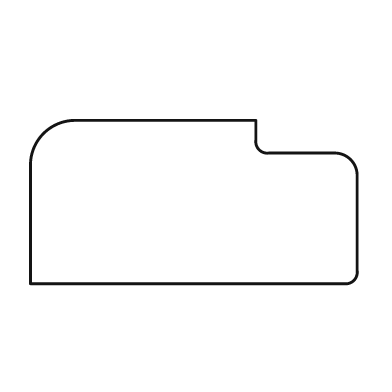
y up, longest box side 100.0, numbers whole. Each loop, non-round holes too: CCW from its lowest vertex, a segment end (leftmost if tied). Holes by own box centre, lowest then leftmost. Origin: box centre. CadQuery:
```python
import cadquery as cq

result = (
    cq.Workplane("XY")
    .moveTo(-50.0, -25.0)
    .lineTo(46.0, -25.0)
    .threePointArc((49.0, -24.0), (50.0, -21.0))
    .lineTo(50.0, 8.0)
    .threePointArc((48.0, 13.0), (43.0, 15.0))
    .lineTo(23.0, 15.0)
    .threePointArc((20.0, 16.0), (19.0, 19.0))
    .lineTo(19.0, 25.0)
    .lineTo(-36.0, 25.0)
    .threePointArc((-46.0, 21.0), (-50.0, 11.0))
    .close()
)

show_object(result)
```